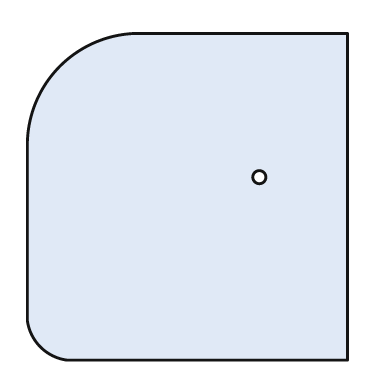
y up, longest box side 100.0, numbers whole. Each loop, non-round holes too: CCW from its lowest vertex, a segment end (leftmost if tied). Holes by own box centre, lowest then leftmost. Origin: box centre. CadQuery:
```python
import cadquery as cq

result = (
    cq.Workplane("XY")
    .moveTo(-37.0, -50.0)
    .lineTo(49.0, -50.0)
    .lineTo(49.0, 50.0)
    .lineTo(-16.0, 50.0)
    .threePointArc((-39.0, 40.0), (-49.0, 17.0))
    .lineTo(-49.0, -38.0)
    .threePointArc((-45.0, -46.0), (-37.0, -50.0))
    .close()
    .moveTo(22.0, 6.0)
    .circle(2.0)
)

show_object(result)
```